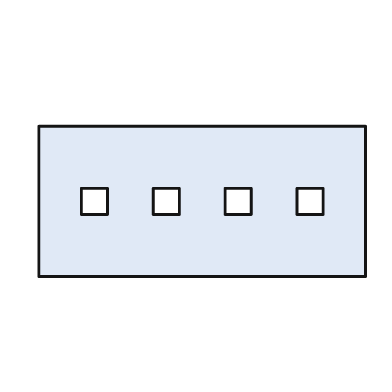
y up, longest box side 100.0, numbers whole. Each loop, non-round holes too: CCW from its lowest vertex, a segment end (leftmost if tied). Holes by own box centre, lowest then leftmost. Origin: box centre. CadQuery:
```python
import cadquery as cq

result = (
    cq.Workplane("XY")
    .moveTo(-50.0, -23.0)
    .lineTo(50.0, -23.0)
    .lineTo(50.0, 23.0)
    .lineTo(-50.0, 23.0)
    .close()
    .moveTo(-37.0, -4.0)
    .lineTo(-29.0, -4.0)
    .lineTo(-29.0, 4.0)
    .lineTo(-37.0, 4.0)
    .close()
    .moveTo(-15.0, -4.0)
    .lineTo(-7.0, -4.0)
    .lineTo(-7.0, 4.0)
    .lineTo(-15.0, 4.0)
    .close()
    .moveTo(7.0, -4.0)
    .lineTo(15.0, -4.0)
    .lineTo(15.0, 4.0)
    .lineTo(7.0, 4.0)
    .close()
    .moveTo(29.0, -4.0)
    .lineTo(37.0, -4.0)
    .lineTo(37.0, 4.0)
    .lineTo(29.0, 4.0)
    .close()
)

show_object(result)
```